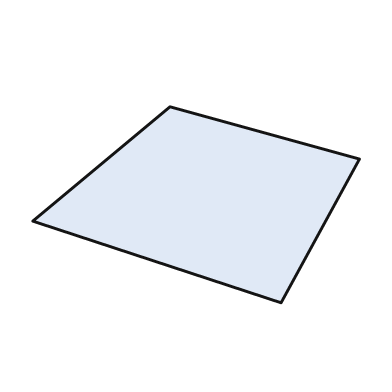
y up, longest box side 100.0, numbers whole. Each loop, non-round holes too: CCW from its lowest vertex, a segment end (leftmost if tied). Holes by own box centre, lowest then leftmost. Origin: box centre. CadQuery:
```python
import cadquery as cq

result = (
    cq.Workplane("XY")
    .moveTo(26.0, -30.0)
    .lineTo(50.0, 14.0)
    .lineTo(-8.0, 30.0)
    .lineTo(-50.0, -5.0)
    .close()
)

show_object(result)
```